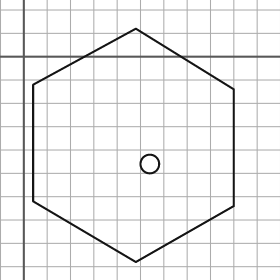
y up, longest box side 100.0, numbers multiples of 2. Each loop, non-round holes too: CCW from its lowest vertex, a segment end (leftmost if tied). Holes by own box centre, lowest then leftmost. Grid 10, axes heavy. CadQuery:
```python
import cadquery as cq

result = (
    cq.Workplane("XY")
    .moveTo(48.0, -88.0)
    .lineTo(90.0, -64.0)
    .lineTo(90.0, -14.0)
    .lineTo(48.0, 12.0)
    .lineTo(4.0, -12.0)
    .lineTo(4.0, -62.0)
    .close()
    .moveTo(54.0, -46.0)
    .circle(4.0)
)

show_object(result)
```